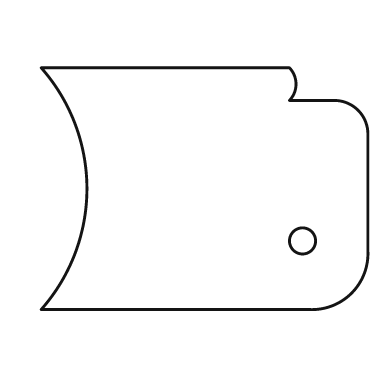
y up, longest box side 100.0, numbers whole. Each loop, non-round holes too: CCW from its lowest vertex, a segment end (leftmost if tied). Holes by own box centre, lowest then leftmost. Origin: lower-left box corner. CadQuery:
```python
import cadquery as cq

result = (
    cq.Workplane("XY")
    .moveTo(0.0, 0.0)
    .lineTo(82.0, 0.0)
    .threePointArc((95.0, 5.0), (100.0, 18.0))
    .lineTo(100.0, 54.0)
    .threePointArc((97.0, 61.0), (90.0, 64.0))
    .lineTo(76.0, 64.0)
    .threePointArc((78.0, 69.0), (76.0, 74.0))
    .lineTo(0.0, 74.0)
    .threePointArc((14.0, 37.0), (0.0, 0.0))
    .close()
    .moveTo(80.0, 21.0)
    .circle(4.0)
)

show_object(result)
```